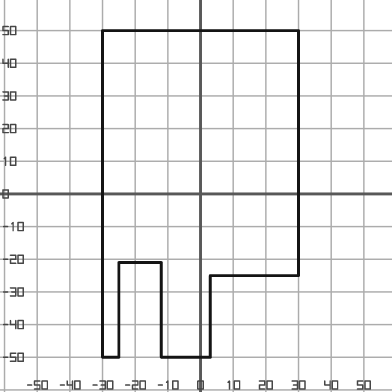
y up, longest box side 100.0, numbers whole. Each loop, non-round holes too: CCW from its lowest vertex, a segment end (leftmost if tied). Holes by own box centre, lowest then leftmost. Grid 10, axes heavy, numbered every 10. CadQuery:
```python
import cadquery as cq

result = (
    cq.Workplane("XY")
    .moveTo(-30.0, -50.0)
    .lineTo(-25.0, -50.0)
    .lineTo(-25.0, -21.0)
    .lineTo(-12.0, -21.0)
    .lineTo(-12.0, -50.0)
    .lineTo(3.0, -50.0)
    .lineTo(3.0, -25.0)
    .lineTo(30.0, -25.0)
    .lineTo(30.0, 50.0)
    .lineTo(-30.0, 50.0)
    .close()
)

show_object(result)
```